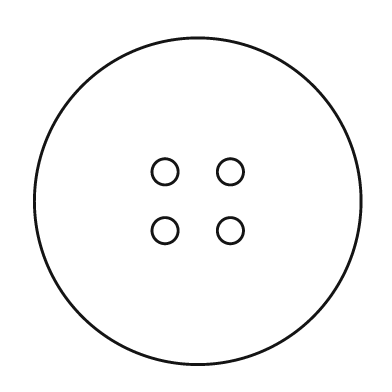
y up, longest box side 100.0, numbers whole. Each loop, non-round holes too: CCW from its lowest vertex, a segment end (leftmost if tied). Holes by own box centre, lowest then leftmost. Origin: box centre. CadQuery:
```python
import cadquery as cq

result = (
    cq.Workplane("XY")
    .moveTo(0.0, 0.0)
    .circle(50.0)
    .moveTo(-10.0, -9.0)
    .circle(4.0)
    .moveTo(10.0, -9.0)
    .circle(4.0)
    .moveTo(-10.0, 9.0)
    .circle(4.0)
    .moveTo(10.0, 9.0)
    .circle(4.0)
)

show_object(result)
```